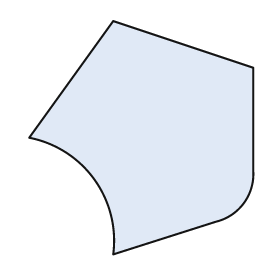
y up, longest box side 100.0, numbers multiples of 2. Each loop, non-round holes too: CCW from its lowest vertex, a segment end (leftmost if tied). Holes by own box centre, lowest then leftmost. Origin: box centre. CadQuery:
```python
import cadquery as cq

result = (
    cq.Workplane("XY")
    .moveTo(-12.0, -50.0)
    .lineTo(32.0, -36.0)
    .threePointArc((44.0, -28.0), (48.0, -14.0))
    .lineTo(48.0, 30.0)
    .lineTo(-12.0, 50.0)
    .lineTo(-48.0, 0.0)
    .threePointArc((-20.0, -18.0), (-12.0, -50.0))
    .close()
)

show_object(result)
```